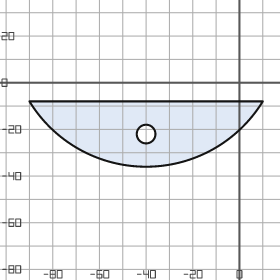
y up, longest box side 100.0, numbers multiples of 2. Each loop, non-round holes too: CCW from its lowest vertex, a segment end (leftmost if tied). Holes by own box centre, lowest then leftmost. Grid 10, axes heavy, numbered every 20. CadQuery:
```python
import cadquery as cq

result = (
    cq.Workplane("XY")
    .moveTo(-90.0, -8.0)
    .threePointArc((-40.0, -36.0), (10.0, -8.0))
    .close()
    .moveTo(-40.0, -22.0)
    .circle(4.0)
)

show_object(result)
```